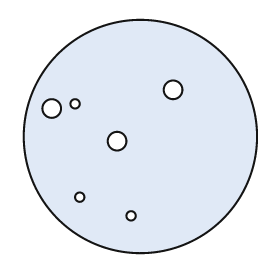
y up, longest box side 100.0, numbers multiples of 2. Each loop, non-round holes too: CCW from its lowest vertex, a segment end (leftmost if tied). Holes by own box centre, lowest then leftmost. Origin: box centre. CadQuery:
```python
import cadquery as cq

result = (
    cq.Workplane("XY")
    .moveTo(0.0, 0.0)
    .circle(50.0)
    .moveTo(-4.0, -34.0)
    .circle(2.0)
    .moveTo(-26.0, -26.0)
    .circle(2.0)
    .moveTo(-10.0, -2.0)
    .circle(4.0)
    .moveTo(-38.0, 12.0)
    .circle(4.0)
    .moveTo(-28.0, 14.0)
    .circle(2.0)
    .moveTo(14.0, 20.0)
    .circle(4.0)
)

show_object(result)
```